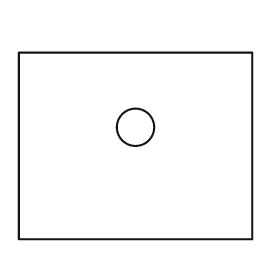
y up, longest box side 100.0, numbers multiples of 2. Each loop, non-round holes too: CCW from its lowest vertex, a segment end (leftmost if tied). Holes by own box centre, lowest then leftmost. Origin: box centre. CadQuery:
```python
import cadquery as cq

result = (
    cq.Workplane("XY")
    .moveTo(-50.0, -40.0)
    .lineTo(50.0, -40.0)
    .lineTo(50.0, 40.0)
    .lineTo(-50.0, 40.0)
    .close()
    .moveTo(0.0, 8.0)
    .circle(8.0)
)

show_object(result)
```